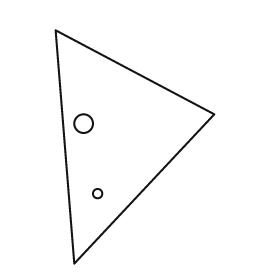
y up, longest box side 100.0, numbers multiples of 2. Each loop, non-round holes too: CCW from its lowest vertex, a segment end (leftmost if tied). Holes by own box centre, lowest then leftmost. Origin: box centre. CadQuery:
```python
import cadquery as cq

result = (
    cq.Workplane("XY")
    .moveTo(-26.0, -50.0)
    .lineTo(34.0, 14.0)
    .lineTo(-34.0, 50.0)
    .close()
    .moveTo(-16.0, -20.0)
    .circle(2.0)
    .moveTo(-22.0, 10.0)
    .circle(4.0)
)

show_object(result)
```